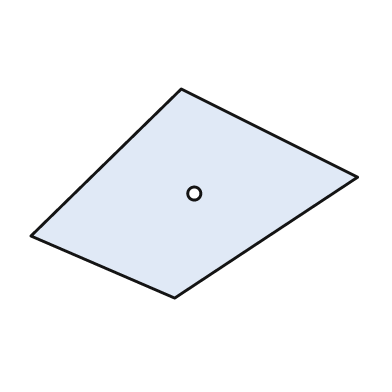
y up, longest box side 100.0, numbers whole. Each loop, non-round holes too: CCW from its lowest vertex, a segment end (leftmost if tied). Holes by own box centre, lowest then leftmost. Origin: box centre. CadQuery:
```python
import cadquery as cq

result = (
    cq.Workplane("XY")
    .moveTo(-6.0, -32.0)
    .lineTo(50.0, 5.0)
    .lineTo(-4.0, 32.0)
    .lineTo(-50.0, -13.0)
    .close()
    .moveTo(0.0, 0.0)
    .circle(2.0)
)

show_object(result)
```